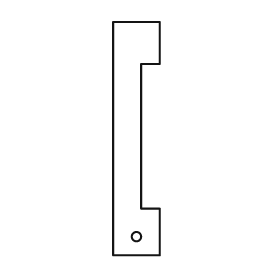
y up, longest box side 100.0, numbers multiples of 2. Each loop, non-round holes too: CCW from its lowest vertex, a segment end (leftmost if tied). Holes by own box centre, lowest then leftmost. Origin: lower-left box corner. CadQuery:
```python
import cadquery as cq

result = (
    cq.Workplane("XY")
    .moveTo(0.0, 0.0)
    .lineTo(20.0, 0.0)
    .lineTo(20.0, 20.0)
    .lineTo(12.0, 20.0)
    .lineTo(12.0, 82.0)
    .lineTo(20.0, 82.0)
    .lineTo(20.0, 100.0)
    .lineTo(0.0, 100.0)
    .close()
    .moveTo(10.0, 8.0)
    .circle(2.0)
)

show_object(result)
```